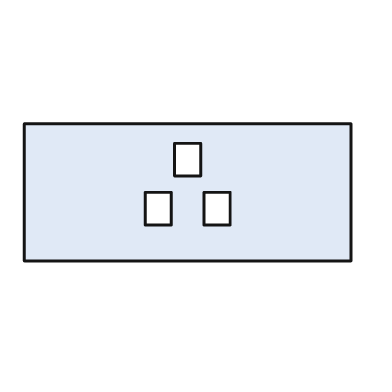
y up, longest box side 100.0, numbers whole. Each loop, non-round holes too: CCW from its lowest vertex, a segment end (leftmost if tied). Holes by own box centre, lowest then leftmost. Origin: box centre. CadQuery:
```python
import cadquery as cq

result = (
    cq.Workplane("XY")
    .moveTo(-50.0, -21.0)
    .lineTo(50.0, -21.0)
    .lineTo(50.0, 21.0)
    .lineTo(-50.0, 21.0)
    .close()
    .moveTo(-13.0, -10.0)
    .lineTo(-5.0, -10.0)
    .lineTo(-5.0, 0.0)
    .lineTo(-13.0, 0.0)
    .close()
    .moveTo(5.0, -10.0)
    .lineTo(13.0, -10.0)
    .lineTo(13.0, 0.0)
    .lineTo(5.0, 0.0)
    .close()
    .moveTo(-4.0, 5.0)
    .lineTo(4.0, 5.0)
    .lineTo(4.0, 15.0)
    .lineTo(-4.0, 15.0)
    .close()
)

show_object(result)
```